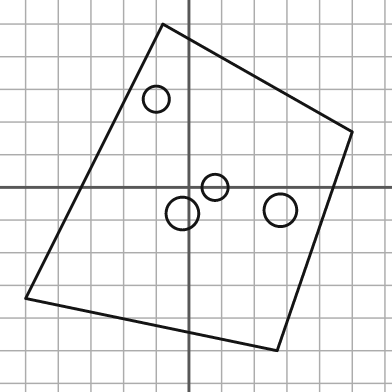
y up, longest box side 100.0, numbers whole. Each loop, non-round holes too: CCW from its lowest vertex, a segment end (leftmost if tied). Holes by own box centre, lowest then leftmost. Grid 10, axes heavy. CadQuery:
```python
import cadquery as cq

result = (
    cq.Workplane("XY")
    .moveTo(27.0, -50.0)
    .lineTo(50.0, 17.0)
    .lineTo(-8.0, 50.0)
    .lineTo(-50.0, -34.0)
    .close()
    .moveTo(-2.0, -8.0)
    .circle(5.0)
    .moveTo(28.0, -7.0)
    .circle(5.0)
    .moveTo(8.0, 0.0)
    .circle(4.0)
    .moveTo(-10.0, 27.0)
    .circle(4.0)
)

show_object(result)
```